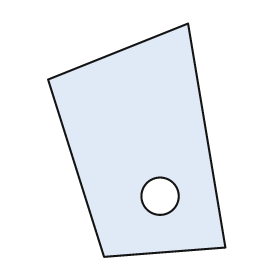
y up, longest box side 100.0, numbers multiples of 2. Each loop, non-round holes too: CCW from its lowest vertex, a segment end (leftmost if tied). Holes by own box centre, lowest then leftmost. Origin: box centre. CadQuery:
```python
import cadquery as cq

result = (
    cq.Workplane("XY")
    .moveTo(-14.0, -50.0)
    .lineTo(38.0, -46.0)
    .lineTo(22.0, 50.0)
    .lineTo(-38.0, 26.0)
    .close()
    .moveTo(10.0, -24.0)
    .circle(8.0)
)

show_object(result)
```